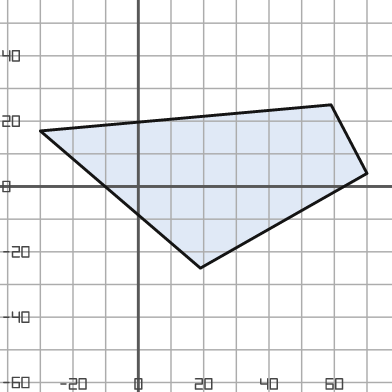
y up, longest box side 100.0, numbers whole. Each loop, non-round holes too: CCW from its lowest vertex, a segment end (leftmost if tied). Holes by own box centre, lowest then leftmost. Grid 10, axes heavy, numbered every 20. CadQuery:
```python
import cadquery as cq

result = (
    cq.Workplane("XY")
    .moveTo(19.0, -25.0)
    .lineTo(70.0, 4.0)
    .lineTo(59.0, 25.0)
    .lineTo(-30.0, 17.0)
    .close()
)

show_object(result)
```